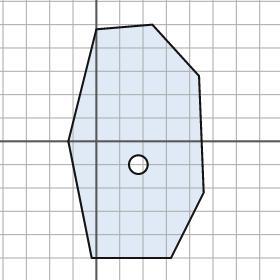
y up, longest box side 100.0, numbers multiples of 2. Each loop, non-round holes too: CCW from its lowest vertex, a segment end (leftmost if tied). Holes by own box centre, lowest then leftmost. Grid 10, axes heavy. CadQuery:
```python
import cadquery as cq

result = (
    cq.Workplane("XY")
    .moveTo(-2.0, -50.0)
    .lineTo(32.0, -50.0)
    .lineTo(46.0, -22.0)
    .lineTo(44.0, 28.0)
    .lineTo(24.0, 50.0)
    .lineTo(0.0, 48.0)
    .lineTo(-12.0, 0.0)
    .close()
    .moveTo(18.0, -10.0)
    .circle(4.0)
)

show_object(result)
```